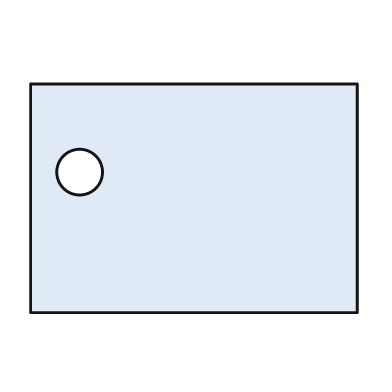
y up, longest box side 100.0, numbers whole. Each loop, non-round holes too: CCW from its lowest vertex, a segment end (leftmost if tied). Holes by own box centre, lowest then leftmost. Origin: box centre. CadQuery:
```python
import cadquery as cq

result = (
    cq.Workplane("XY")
    .moveTo(-50.0, -35.0)
    .lineTo(50.0, -35.0)
    .lineTo(50.0, 35.0)
    .lineTo(-50.0, 35.0)
    .close()
    .moveTo(-35.0, 8.0)
    .circle(7.0)
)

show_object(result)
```